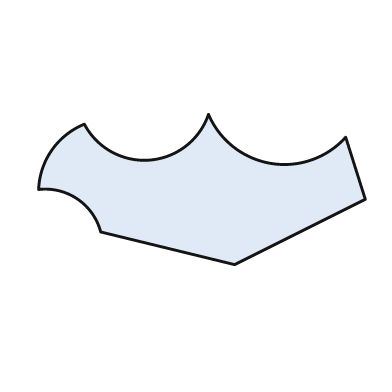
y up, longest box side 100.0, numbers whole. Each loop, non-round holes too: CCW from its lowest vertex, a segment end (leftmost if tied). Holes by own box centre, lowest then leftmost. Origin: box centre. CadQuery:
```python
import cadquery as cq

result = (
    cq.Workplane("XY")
    .moveTo(10.0, -23.0)
    .lineTo(50.0, -3.0)
    .lineTo(44.0, 16.0)
    .threePointArc((21.0, 8.0), (2.0, 23.0))
    .threePointArc((-16.0, 9.0), (-36.0, 20.0))
    .threePointArc((-46.0, 12.0), (-50.0, 0.0))
    .threePointArc((-38.0, -3.0), (-31.0, -13.0))
    .close()
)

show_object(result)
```